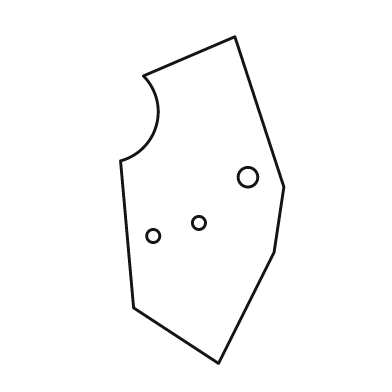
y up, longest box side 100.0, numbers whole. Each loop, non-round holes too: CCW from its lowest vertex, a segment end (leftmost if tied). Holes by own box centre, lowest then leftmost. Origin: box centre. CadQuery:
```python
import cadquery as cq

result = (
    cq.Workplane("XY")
    .moveTo(5.0, -50.0)
    .lineTo(22.0, -16.0)
    .lineTo(25.0, 4.0)
    .lineTo(10.0, 50.0)
    .lineTo(-18.0, 38.0)
    .threePointArc((-14.0, 23.0), (-25.0, 12.0))
    .lineTo(-21.0, -33.0)
    .close()
    .moveTo(-15.0, -11.0)
    .circle(2.0)
    .moveTo(-1.0, -7.0)
    .circle(2.0)
    .moveTo(14.0, 7.0)
    .circle(3.0)
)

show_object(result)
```